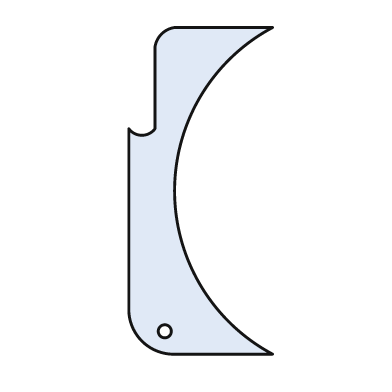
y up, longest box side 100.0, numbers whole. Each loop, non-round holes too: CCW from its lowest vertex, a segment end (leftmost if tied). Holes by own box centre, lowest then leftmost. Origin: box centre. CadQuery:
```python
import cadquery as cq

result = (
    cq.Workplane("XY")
    .moveTo(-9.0, -50.0)
    .lineTo(22.0, -50.0)
    .threePointArc((-8.0, 0.0), (22.0, 50.0))
    .lineTo(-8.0, 50.0)
    .threePointArc((-12.0, 48.0), (-14.0, 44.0))
    .lineTo(-14.0, 19.0)
    .threePointArc((-18.0, 17.0), (-22.0, 19.0))
    .lineTo(-22.0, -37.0)
    .threePointArc((-18.0, -46.0), (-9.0, -50.0))
    .close()
    .moveTo(-11.0, -43.0)
    .circle(2.0)
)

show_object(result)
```